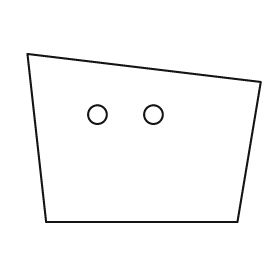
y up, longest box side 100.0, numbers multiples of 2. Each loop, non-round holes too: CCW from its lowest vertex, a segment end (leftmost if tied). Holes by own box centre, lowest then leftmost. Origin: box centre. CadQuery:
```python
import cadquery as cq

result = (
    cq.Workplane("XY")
    .moveTo(-42.0, -36.0)
    .lineTo(40.0, -36.0)
    .lineTo(50.0, 24.0)
    .lineTo(-50.0, 36.0)
    .close()
    .moveTo(-20.0, 10.0)
    .circle(4.0)
    .moveTo(4.0, 10.0)
    .circle(4.0)
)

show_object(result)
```